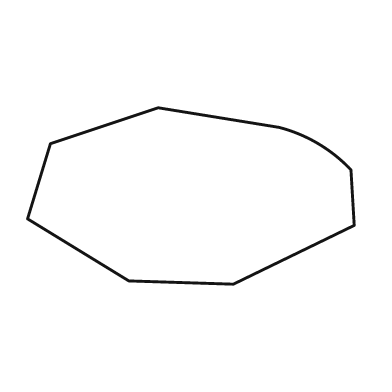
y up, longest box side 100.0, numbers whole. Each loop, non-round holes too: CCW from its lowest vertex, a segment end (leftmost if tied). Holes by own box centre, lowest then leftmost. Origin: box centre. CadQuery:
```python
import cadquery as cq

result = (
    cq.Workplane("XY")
    .moveTo(13.0, -27.0)
    .lineTo(50.0, -9.0)
    .lineTo(49.0, 8.0)
    .threePointArc((39.0, 16.0), (27.0, 21.0))
    .lineTo(-10.0, 27.0)
    .lineTo(-43.0, 16.0)
    .lineTo(-50.0, -7.0)
    .lineTo(-19.0, -26.0)
    .close()
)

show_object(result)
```